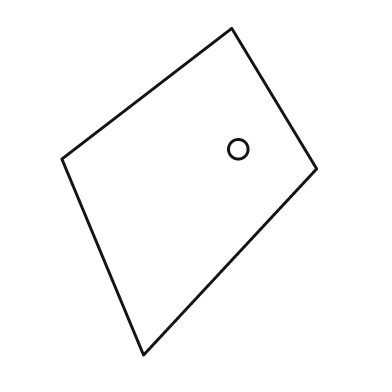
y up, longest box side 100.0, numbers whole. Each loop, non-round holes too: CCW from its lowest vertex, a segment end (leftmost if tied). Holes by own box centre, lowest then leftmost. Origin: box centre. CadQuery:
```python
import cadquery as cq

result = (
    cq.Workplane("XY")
    .moveTo(-14.0, -50.0)
    .lineTo(39.0, 7.0)
    .lineTo(13.0, 50.0)
    .lineTo(-39.0, 10.0)
    .close()
    .moveTo(15.0, 13.0)
    .circle(3.0)
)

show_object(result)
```